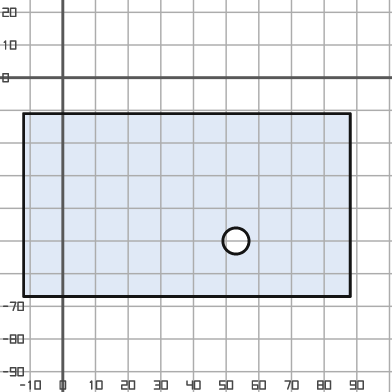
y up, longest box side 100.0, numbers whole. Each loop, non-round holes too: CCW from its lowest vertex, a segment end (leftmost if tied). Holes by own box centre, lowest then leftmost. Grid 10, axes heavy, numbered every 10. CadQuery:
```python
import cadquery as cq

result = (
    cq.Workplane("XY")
    .moveTo(-12.0, -67.0)
    .lineTo(88.0, -67.0)
    .lineTo(88.0, -11.0)
    .lineTo(-12.0, -11.0)
    .close()
    .moveTo(53.0, -50.0)
    .circle(4.0)
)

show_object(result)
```